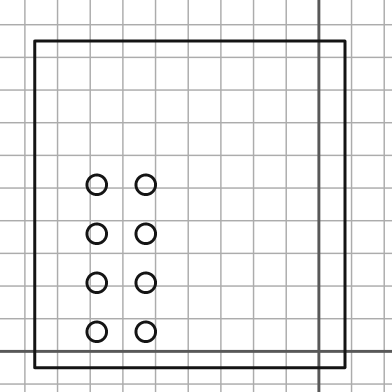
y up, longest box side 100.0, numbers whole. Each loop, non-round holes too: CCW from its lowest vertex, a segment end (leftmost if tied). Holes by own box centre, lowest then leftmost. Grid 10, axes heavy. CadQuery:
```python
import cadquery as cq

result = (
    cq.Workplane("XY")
    .moveTo(-87.0, -5.0)
    .lineTo(8.0, -5.0)
    .lineTo(8.0, 95.0)
    .lineTo(-87.0, 95.0)
    .close()
    .moveTo(-68.0, 6.0)
    .circle(3.0)
    .moveTo(-53.0, 6.0)
    .circle(3.0)
    .moveTo(-68.0, 21.0)
    .circle(3.0)
    .moveTo(-53.0, 21.0)
    .circle(3.0)
    .moveTo(-68.0, 36.0)
    .circle(3.0)
    .moveTo(-53.0, 36.0)
    .circle(3.0)
    .moveTo(-68.0, 51.0)
    .circle(3.0)
    .moveTo(-53.0, 51.0)
    .circle(3.0)
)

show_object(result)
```